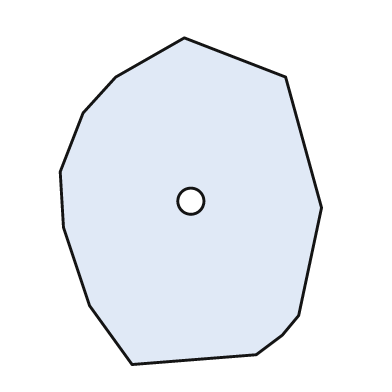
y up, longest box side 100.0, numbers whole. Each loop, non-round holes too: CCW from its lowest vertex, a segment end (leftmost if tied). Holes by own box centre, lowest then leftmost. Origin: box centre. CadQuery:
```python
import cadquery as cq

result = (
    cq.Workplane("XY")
    .moveTo(-18.0, -50.0)
    .lineTo(20.0, -47.0)
    .lineTo(28.0, -41.0)
    .lineTo(33.0, -35.0)
    .lineTo(40.0, -2.0)
    .lineTo(29.0, 38.0)
    .lineTo(-2.0, 50.0)
    .lineTo(-23.0, 38.0)
    .lineTo(-33.0, 27.0)
    .lineTo(-40.0, 9.0)
    .lineTo(-39.0, -8.0)
    .lineTo(-31.0, -32.0)
    .close()
    .moveTo(0.0, 0.0)
    .circle(4.0)
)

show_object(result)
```